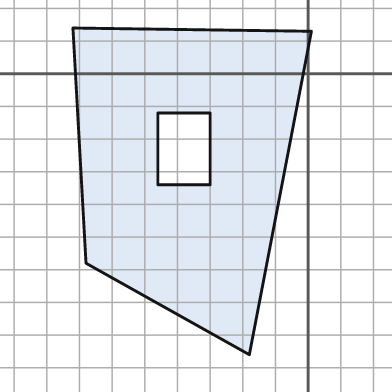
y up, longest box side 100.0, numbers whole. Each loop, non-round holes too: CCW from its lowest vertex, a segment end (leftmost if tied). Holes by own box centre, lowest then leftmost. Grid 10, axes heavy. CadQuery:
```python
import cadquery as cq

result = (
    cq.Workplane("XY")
    .moveTo(-18.0, -86.0)
    .lineTo(1.0, 13.0)
    .lineTo(-72.0, 14.0)
    .lineTo(-68.0, -58.0)
    .close()
    .moveTo(-46.0, -34.0)
    .lineTo(-30.0, -34.0)
    .lineTo(-30.0, -12.0)
    .lineTo(-46.0, -12.0)
    .close()
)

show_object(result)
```